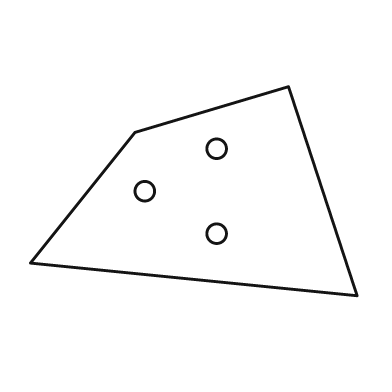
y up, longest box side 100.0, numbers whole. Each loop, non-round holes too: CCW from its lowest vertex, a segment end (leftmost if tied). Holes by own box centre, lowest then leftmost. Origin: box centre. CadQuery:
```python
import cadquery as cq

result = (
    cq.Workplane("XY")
    .moveTo(50.0, -32.0)
    .lineTo(29.0, 32.0)
    .lineTo(-18.0, 18.0)
    .lineTo(-50.0, -22.0)
    .close()
    .moveTo(7.0, -13.0)
    .circle(3.0)
    .moveTo(-15.0, 0.0)
    .circle(3.0)
    .moveTo(7.0, 13.0)
    .circle(3.0)
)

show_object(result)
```